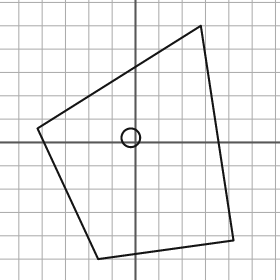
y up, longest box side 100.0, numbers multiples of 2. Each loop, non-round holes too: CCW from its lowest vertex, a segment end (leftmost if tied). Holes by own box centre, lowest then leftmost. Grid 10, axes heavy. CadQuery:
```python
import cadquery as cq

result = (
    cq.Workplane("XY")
    .moveTo(-16.0, -50.0)
    .lineTo(42.0, -42.0)
    .lineTo(28.0, 50.0)
    .lineTo(-42.0, 6.0)
    .close()
    .moveTo(-2.0, 2.0)
    .circle(4.0)
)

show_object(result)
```